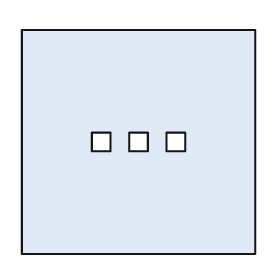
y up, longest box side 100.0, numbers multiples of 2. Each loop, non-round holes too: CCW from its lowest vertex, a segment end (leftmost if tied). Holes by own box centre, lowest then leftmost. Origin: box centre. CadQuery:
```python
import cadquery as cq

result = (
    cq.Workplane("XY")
    .moveTo(-50.0, -48.0)
    .lineTo(50.0, -48.0)
    .lineTo(50.0, 48.0)
    .lineTo(-50.0, 48.0)
    .close()
    .moveTo(-20.0, -4.0)
    .lineTo(-12.0, -4.0)
    .lineTo(-12.0, 4.0)
    .lineTo(-20.0, 4.0)
    .close()
    .moveTo(-4.0, -4.0)
    .lineTo(4.0, -4.0)
    .lineTo(4.0, 4.0)
    .lineTo(-4.0, 4.0)
    .close()
    .moveTo(12.0, -4.0)
    .lineTo(20.0, -4.0)
    .lineTo(20.0, 4.0)
    .lineTo(12.0, 4.0)
    .close()
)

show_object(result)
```